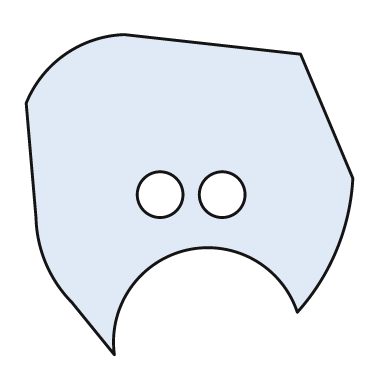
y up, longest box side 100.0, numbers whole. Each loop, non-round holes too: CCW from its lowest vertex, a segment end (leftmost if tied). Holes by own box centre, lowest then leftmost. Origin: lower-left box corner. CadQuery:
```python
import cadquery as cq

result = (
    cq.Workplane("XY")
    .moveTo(27.0, 0.0)
    .threePointArc((49.0, 32.0), (83.0, 13.0))
    .threePointArc((95.0, 32.0), (100.0, 54.0))
    .lineTo(84.0, 92.0)
    .lineTo(30.0, 98.0)
    .threePointArc((12.0, 92.0), (0.0, 77.0))
    .lineTo(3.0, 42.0)
    .threePointArc((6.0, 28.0), (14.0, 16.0))
    .close()
    .moveTo(41.0, 49.0)
    .circle(7.0)
    .moveTo(60.0, 49.0)
    .circle(7.0)
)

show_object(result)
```